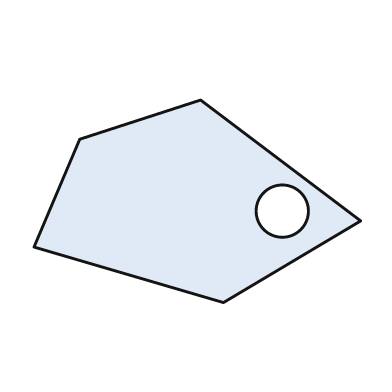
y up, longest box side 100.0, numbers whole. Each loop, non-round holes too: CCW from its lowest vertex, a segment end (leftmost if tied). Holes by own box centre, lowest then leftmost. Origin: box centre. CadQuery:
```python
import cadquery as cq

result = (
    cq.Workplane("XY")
    .moveTo(8.0, -31.0)
    .lineTo(50.0, -6.0)
    .lineTo(1.0, 31.0)
    .lineTo(-36.0, 19.0)
    .lineTo(-50.0, -14.0)
    .close()
    .moveTo(26.0, -3.0)
    .circle(8.0)
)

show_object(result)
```